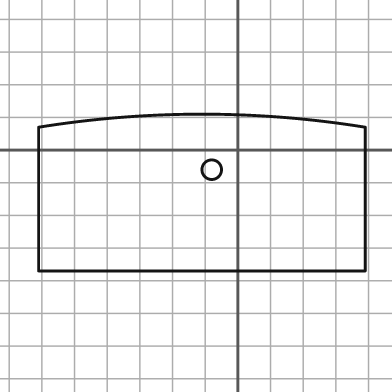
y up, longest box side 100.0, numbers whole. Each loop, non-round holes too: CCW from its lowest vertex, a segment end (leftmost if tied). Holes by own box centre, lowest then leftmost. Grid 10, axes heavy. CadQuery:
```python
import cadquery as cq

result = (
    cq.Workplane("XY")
    .moveTo(-61.0, -37.0)
    .lineTo(39.0, -37.0)
    .lineTo(39.0, 7.0)
    .threePointArc((-11.0, 11.0), (-61.0, 7.0))
    .close()
    .moveTo(-8.0, -6.0)
    .circle(3.0)
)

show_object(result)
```